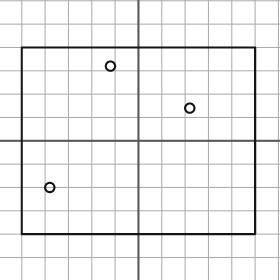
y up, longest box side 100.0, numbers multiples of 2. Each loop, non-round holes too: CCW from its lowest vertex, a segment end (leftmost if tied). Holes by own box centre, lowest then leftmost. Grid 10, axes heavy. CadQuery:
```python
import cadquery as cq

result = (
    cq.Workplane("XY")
    .moveTo(-50.0, -40.0)
    .lineTo(50.0, -40.0)
    .lineTo(50.0, 40.0)
    .lineTo(-50.0, 40.0)
    .close()
    .moveTo(-38.0, -20.0)
    .circle(2.0)
    .moveTo(22.0, 14.0)
    .circle(2.0)
    .moveTo(-12.0, 32.0)
    .circle(2.0)
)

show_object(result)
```